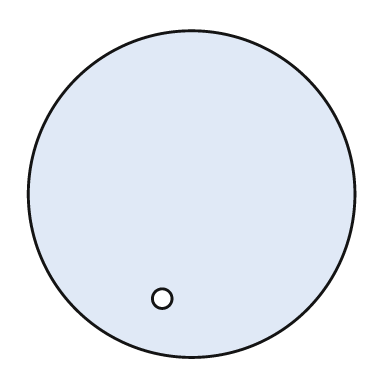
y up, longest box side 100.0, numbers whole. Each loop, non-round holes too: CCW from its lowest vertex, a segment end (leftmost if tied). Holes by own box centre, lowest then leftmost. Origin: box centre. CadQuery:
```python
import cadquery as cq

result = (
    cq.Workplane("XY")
    .moveTo(0.0, 0.0)
    .circle(50.0)
    .moveTo(-9.0, -32.0)
    .circle(3.0)
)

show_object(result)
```